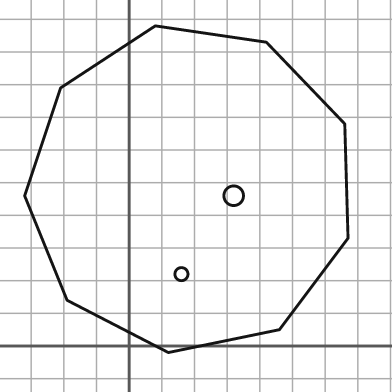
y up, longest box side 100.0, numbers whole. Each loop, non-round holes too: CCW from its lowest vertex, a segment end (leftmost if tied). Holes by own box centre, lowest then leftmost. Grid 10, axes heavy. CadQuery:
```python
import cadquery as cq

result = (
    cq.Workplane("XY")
    .moveTo(12.0, -2.0)
    .lineTo(46.0, 5.0)
    .lineTo(67.0, 33.0)
    .lineTo(66.0, 68.0)
    .lineTo(42.0, 93.0)
    .lineTo(8.0, 98.0)
    .lineTo(-21.0, 79.0)
    .lineTo(-32.0, 46.0)
    .lineTo(-19.0, 14.0)
    .close()
    .moveTo(16.0, 22.0)
    .circle(2.0)
    .moveTo(32.0, 46.0)
    .circle(3.0)
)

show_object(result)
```